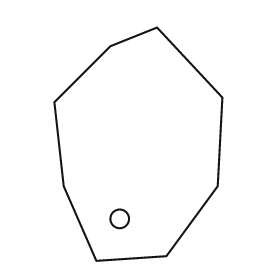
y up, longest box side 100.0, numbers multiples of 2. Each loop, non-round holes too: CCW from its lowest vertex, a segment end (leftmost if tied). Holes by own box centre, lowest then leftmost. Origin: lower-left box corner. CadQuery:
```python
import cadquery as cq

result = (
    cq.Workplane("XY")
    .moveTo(18.0, 0.0)
    .lineTo(48.0, 2.0)
    .lineTo(70.0, 32.0)
    .lineTo(72.0, 70.0)
    .lineTo(44.0, 100.0)
    .lineTo(24.0, 92.0)
    .lineTo(0.0, 68.0)
    .lineTo(4.0, 32.0)
    .close()
    .moveTo(28.0, 18.0)
    .circle(4.0)
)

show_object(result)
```